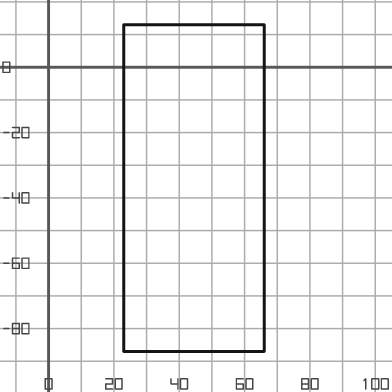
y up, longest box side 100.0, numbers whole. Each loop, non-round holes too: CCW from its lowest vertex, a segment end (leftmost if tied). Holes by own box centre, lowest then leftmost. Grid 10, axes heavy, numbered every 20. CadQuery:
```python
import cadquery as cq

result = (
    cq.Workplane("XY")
    .moveTo(23.0, -87.0)
    .lineTo(66.0, -87.0)
    .lineTo(66.0, 13.0)
    .lineTo(23.0, 13.0)
    .close()
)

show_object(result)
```